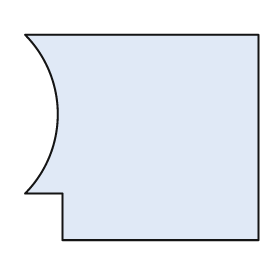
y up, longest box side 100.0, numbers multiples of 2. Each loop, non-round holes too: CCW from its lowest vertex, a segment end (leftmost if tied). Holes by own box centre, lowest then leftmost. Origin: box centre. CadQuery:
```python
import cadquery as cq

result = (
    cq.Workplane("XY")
    .moveTo(-34.0, -44.0)
    .lineTo(50.0, -44.0)
    .lineTo(50.0, 44.0)
    .lineTo(-50.0, 44.0)
    .threePointArc((-36.0, 10.0), (-50.0, -24.0))
    .lineTo(-34.0, -24.0)
    .close()
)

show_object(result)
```